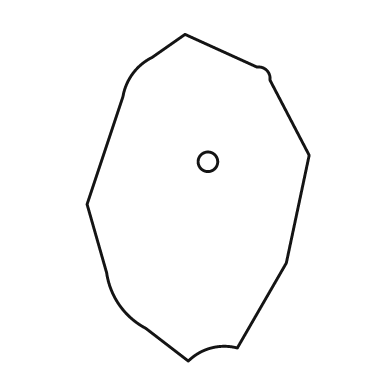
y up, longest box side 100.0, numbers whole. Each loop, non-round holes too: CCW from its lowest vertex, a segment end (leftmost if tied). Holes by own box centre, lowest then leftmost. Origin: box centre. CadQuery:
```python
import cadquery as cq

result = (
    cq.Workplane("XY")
    .moveTo(-3.0, -50.0)
    .threePointArc((4.0, -46.0), (12.0, -46.0))
    .lineTo(27.0, -20.0)
    .lineTo(34.0, 13.0)
    .lineTo(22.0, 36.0)
    .threePointArc((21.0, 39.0), (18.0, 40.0))
    .lineTo(-4.0, 50.0)
    .lineTo(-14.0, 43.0)
    .threePointArc((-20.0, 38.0), (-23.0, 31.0))
    .lineTo(-34.0, -2.0)
    .lineTo(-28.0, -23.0)
    .threePointArc((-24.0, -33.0), (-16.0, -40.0))
    .close()
    .moveTo(3.0, 11.0)
    .circle(3.0)
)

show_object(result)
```